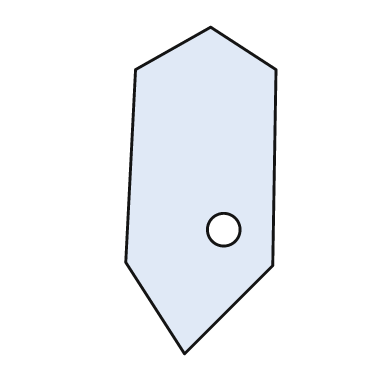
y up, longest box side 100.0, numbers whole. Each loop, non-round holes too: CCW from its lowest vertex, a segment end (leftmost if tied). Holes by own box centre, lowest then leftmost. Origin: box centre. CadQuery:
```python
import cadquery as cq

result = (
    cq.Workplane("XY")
    .moveTo(-5.0, -50.0)
    .lineTo(22.0, -23.0)
    .lineTo(23.0, 37.0)
    .lineTo(3.0, 50.0)
    .lineTo(-20.0, 37.0)
    .lineTo(-23.0, -22.0)
    .close()
    .moveTo(7.0, -12.0)
    .circle(5.0)
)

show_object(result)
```